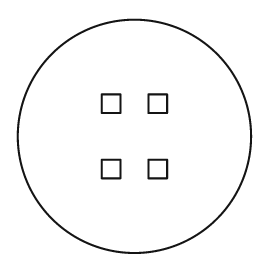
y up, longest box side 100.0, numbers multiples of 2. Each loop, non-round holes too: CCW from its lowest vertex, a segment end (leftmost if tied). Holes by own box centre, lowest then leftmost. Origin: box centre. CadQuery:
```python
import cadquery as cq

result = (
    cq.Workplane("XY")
    .moveTo(0.0, 0.0)
    .circle(50.0)
    .moveTo(-14.0, -18.0)
    .lineTo(-6.0, -18.0)
    .lineTo(-6.0, -10.0)
    .lineTo(-14.0, -10.0)
    .close()
    .moveTo(6.0, -18.0)
    .lineTo(14.0, -18.0)
    .lineTo(14.0, -10.0)
    .lineTo(6.0, -10.0)
    .close()
    .moveTo(-14.0, 10.0)
    .lineTo(-6.0, 10.0)
    .lineTo(-6.0, 18.0)
    .lineTo(-14.0, 18.0)
    .close()
    .moveTo(6.0, 10.0)
    .lineTo(14.0, 10.0)
    .lineTo(14.0, 18.0)
    .lineTo(6.0, 18.0)
    .close()
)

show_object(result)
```